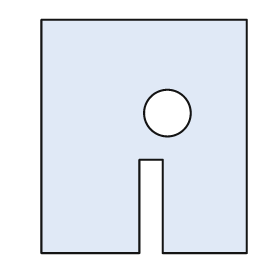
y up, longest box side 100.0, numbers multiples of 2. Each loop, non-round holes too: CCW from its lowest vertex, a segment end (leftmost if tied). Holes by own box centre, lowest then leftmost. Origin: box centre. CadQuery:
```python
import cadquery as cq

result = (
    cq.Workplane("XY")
    .moveTo(-44.0, -50.0)
    .lineTo(-2.0, -50.0)
    .lineTo(-2.0, -10.0)
    .lineTo(8.0, -10.0)
    .lineTo(8.0, -50.0)
    .lineTo(44.0, -50.0)
    .lineTo(44.0, 50.0)
    .lineTo(-44.0, 50.0)
    .close()
    .moveTo(10.0, 10.0)
    .circle(10.0)
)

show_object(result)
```